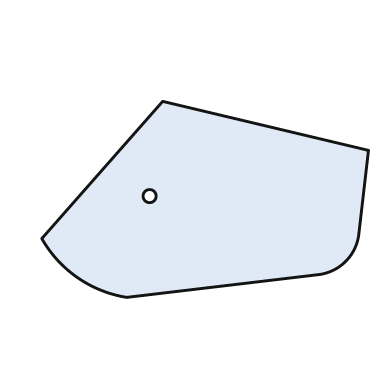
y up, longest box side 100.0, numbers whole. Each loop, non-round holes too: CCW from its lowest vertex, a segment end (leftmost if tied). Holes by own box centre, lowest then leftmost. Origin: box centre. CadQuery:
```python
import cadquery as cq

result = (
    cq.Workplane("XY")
    .moveTo(-24.0, -30.0)
    .lineTo(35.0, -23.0)
    .threePointArc((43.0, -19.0), (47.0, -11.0))
    .lineTo(50.0, 15.0)
    .lineTo(-13.0, 30.0)
    .lineTo(-50.0, -12.0)
    .threePointArc((-39.0, -24.0), (-24.0, -30.0))
    .close()
    .moveTo(-17.0, 1.0)
    .circle(2.0)
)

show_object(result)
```